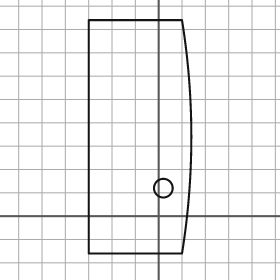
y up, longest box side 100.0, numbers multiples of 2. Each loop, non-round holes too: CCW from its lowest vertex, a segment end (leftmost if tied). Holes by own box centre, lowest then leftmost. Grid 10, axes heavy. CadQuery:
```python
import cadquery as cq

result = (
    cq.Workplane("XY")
    .moveTo(-30.0, -16.0)
    .lineTo(10.0, -16.0)
    .threePointArc((14.0, 34.0), (10.0, 84.0))
    .lineTo(-30.0, 84.0)
    .close()
    .moveTo(2.0, 12.0)
    .circle(4.0)
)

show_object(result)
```